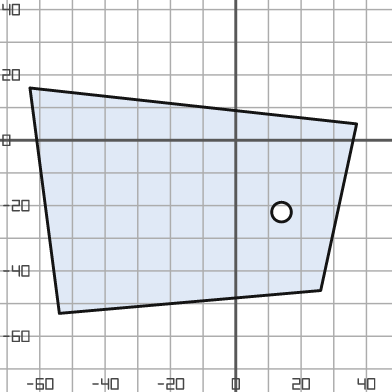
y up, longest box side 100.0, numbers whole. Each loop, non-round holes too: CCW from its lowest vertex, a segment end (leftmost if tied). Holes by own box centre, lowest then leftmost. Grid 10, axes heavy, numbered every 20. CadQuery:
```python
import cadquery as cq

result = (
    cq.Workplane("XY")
    .moveTo(-54.0, -53.0)
    .lineTo(26.0, -46.0)
    .lineTo(37.0, 5.0)
    .lineTo(-63.0, 16.0)
    .close()
    .moveTo(14.0, -22.0)
    .circle(3.0)
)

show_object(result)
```